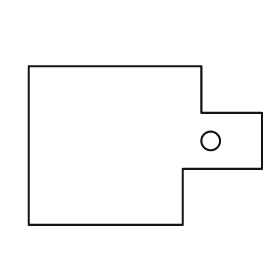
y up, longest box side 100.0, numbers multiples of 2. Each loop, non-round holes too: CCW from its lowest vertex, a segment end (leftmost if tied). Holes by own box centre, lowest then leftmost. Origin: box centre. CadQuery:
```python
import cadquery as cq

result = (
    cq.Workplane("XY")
    .moveTo(-50.0, -34.0)
    .lineTo(16.0, -34.0)
    .lineTo(16.0, -10.0)
    .lineTo(50.0, -10.0)
    .lineTo(50.0, 14.0)
    .lineTo(24.0, 14.0)
    .lineTo(24.0, 34.0)
    .lineTo(-50.0, 34.0)
    .close()
    .moveTo(28.0, 2.0)
    .circle(4.0)
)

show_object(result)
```